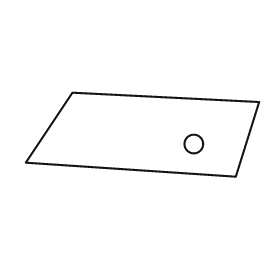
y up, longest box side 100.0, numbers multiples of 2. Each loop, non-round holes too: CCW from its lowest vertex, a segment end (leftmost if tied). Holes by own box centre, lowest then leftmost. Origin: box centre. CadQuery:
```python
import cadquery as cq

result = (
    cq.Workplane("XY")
    .moveTo(40.0, -18.0)
    .lineTo(50.0, 14.0)
    .lineTo(-30.0, 18.0)
    .lineTo(-50.0, -12.0)
    .close()
    .moveTo(22.0, -4.0)
    .circle(4.0)
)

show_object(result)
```